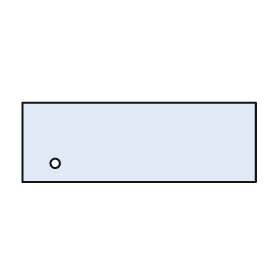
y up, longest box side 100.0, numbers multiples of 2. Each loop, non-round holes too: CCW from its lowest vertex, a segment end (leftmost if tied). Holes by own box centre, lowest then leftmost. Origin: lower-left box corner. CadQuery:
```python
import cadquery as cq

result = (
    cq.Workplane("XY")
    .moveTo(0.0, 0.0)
    .lineTo(100.0, 0.0)
    .lineTo(100.0, 34.0)
    .lineTo(0.0, 34.0)
    .close()
    .moveTo(14.0, 8.0)
    .circle(2.0)
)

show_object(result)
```